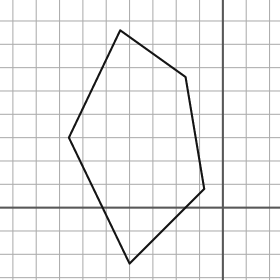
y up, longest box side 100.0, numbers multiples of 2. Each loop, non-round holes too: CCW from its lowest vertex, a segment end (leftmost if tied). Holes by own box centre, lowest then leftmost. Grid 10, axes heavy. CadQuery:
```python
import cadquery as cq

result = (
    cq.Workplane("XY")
    .moveTo(-40.0, -24.0)
    .lineTo(-8.0, 8.0)
    .lineTo(-16.0, 56.0)
    .lineTo(-44.0, 76.0)
    .lineTo(-66.0, 30.0)
    .close()
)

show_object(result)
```